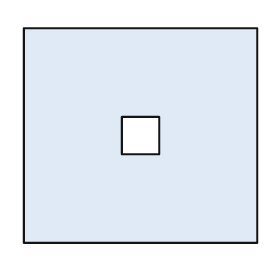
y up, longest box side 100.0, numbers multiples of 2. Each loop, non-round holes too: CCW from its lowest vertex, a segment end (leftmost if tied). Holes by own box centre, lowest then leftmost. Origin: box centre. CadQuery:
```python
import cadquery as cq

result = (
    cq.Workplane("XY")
    .moveTo(-50.0, -46.0)
    .lineTo(50.0, -46.0)
    .lineTo(50.0, 46.0)
    .lineTo(-50.0, 46.0)
    .close()
    .moveTo(-8.0, -8.0)
    .lineTo(8.0, -8.0)
    .lineTo(8.0, 8.0)
    .lineTo(-8.0, 8.0)
    .close()
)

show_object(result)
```